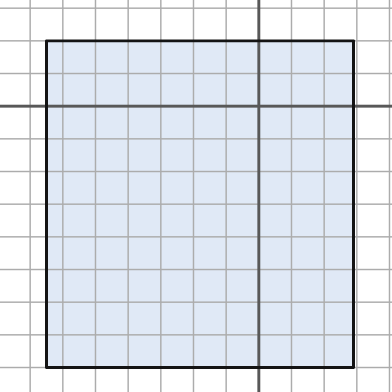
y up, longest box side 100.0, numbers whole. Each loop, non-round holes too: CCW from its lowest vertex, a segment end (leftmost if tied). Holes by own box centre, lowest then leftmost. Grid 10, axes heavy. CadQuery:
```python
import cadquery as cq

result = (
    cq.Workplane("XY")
    .moveTo(-65.0, -80.0)
    .lineTo(29.0, -80.0)
    .lineTo(29.0, 20.0)
    .lineTo(-65.0, 20.0)
    .close()
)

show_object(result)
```